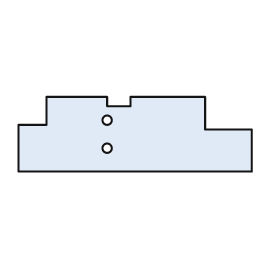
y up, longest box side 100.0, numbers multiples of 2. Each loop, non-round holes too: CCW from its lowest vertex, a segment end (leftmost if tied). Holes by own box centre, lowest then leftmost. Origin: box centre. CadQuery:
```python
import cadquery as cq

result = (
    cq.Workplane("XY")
    .moveTo(-50.0, -16.0)
    .lineTo(50.0, -16.0)
    .lineTo(50.0, 2.0)
    .lineTo(30.0, 2.0)
    .lineTo(30.0, 16.0)
    .lineTo(-2.0, 16.0)
    .lineTo(-2.0, 12.0)
    .lineTo(-12.0, 12.0)
    .lineTo(-12.0, 16.0)
    .lineTo(-38.0, 16.0)
    .lineTo(-38.0, 4.0)
    .lineTo(-50.0, 4.0)
    .close()
    .moveTo(-12.0, -6.0)
    .circle(2.0)
    .moveTo(-12.0, 6.0)
    .circle(2.0)
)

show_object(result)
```